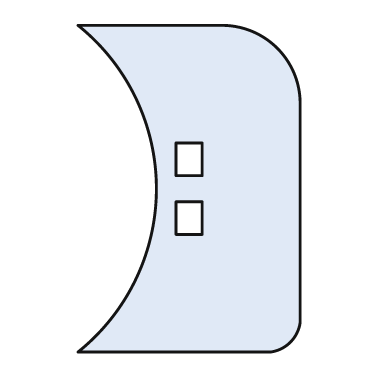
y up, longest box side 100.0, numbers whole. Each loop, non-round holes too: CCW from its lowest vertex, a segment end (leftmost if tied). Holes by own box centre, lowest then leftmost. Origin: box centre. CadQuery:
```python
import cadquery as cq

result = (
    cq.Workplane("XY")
    .moveTo(-34.0, -50.0)
    .lineTo(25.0, -50.0)
    .threePointArc((31.0, -47.0), (34.0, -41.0))
    .lineTo(34.0, 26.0)
    .threePointArc((27.0, 43.0), (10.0, 50.0))
    .lineTo(-34.0, 50.0)
    .threePointArc((-10.0, 0.0), (-34.0, -50.0))
    .close()
    .moveTo(-4.0, -14.0)
    .lineTo(4.0, -14.0)
    .lineTo(4.0, -4.0)
    .lineTo(-4.0, -4.0)
    .close()
    .moveTo(-4.0, 4.0)
    .lineTo(4.0, 4.0)
    .lineTo(4.0, 14.0)
    .lineTo(-4.0, 14.0)
    .close()
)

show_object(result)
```